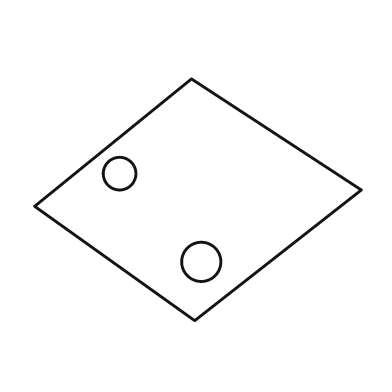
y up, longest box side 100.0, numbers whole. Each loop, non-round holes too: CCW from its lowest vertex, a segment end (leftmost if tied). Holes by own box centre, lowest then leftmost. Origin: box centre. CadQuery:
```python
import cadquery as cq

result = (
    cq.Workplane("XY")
    .moveTo(-1.0, -37.0)
    .lineTo(50.0, 3.0)
    .lineTo(-2.0, 37.0)
    .lineTo(-50.0, -2.0)
    .close()
    .moveTo(1.0, -19.0)
    .circle(6.0)
    .moveTo(-24.0, 8.0)
    .circle(5.0)
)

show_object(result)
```